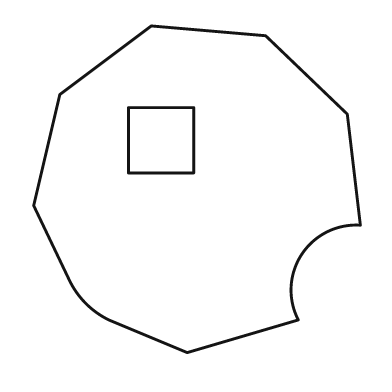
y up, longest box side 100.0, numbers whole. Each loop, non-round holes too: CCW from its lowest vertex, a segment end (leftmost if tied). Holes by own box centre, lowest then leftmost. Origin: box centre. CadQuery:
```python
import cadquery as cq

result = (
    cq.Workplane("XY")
    .moveTo(-3.0, -50.0)
    .lineTo(31.0, -40.0)
    .threePointArc((32.0, -20.0), (50.0, -11.0))
    .lineTo(46.0, 23.0)
    .lineTo(21.0, 47.0)
    .lineTo(-14.0, 50.0)
    .lineTo(-42.0, 29.0)
    .lineTo(-50.0, -5.0)
    .lineTo(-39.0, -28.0)
    .threePointArc((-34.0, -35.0), (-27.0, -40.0))
    .close()
    .moveTo(-21.0, 5.0)
    .lineTo(-1.0, 5.0)
    .lineTo(-1.0, 25.0)
    .lineTo(-21.0, 25.0)
    .close()
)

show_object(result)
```